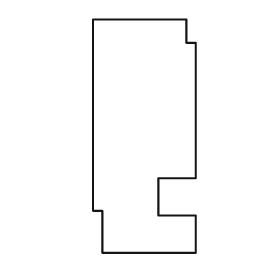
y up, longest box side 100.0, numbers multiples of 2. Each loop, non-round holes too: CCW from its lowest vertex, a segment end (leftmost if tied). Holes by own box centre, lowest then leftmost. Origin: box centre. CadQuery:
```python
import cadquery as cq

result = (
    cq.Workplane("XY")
    .moveTo(-18.0, -50.0)
    .lineTo(22.0, -50.0)
    .lineTo(22.0, -34.0)
    .lineTo(6.0, -34.0)
    .lineTo(6.0, -18.0)
    .lineTo(22.0, -18.0)
    .lineTo(22.0, 40.0)
    .lineTo(18.0, 40.0)
    .lineTo(18.0, 50.0)
    .lineTo(-22.0, 50.0)
    .lineTo(-22.0, -32.0)
    .lineTo(-18.0, -32.0)
    .close()
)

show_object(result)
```